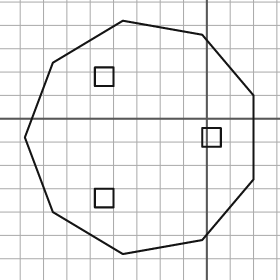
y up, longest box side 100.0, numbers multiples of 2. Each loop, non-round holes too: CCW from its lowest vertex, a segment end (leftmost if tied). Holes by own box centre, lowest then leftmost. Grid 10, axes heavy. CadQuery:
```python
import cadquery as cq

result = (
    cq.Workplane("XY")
    .moveTo(-36.0, -58.0)
    .lineTo(-2.0, -52.0)
    .lineTo(20.0, -26.0)
    .lineTo(20.0, 10.0)
    .lineTo(-2.0, 36.0)
    .lineTo(-36.0, 42.0)
    .lineTo(-66.0, 24.0)
    .lineTo(-78.0, -8.0)
    .lineTo(-66.0, -40.0)
    .close()
    .moveTo(-48.0, -38.0)
    .lineTo(-40.0, -38.0)
    .lineTo(-40.0, -30.0)
    .lineTo(-48.0, -30.0)
    .close()
    .moveTo(-2.0, -12.0)
    .lineTo(6.0, -12.0)
    .lineTo(6.0, -4.0)
    .lineTo(-2.0, -4.0)
    .close()
    .moveTo(-48.0, 14.0)
    .lineTo(-40.0, 14.0)
    .lineTo(-40.0, 22.0)
    .lineTo(-48.0, 22.0)
    .close()
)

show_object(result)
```